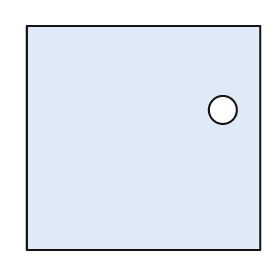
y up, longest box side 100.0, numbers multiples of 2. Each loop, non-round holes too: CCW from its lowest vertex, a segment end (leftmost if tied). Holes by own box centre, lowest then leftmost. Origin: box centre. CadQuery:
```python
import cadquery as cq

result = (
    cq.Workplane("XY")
    .moveTo(-50.0, -48.0)
    .lineTo(50.0, -48.0)
    .lineTo(50.0, 48.0)
    .lineTo(-50.0, 48.0)
    .close()
    .moveTo(34.0, 12.0)
    .circle(6.0)
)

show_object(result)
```